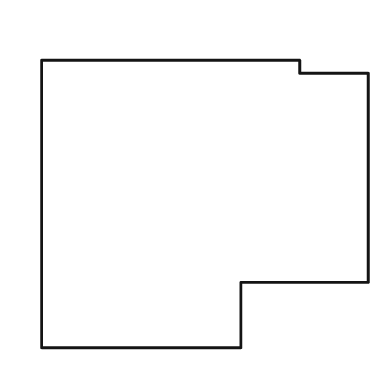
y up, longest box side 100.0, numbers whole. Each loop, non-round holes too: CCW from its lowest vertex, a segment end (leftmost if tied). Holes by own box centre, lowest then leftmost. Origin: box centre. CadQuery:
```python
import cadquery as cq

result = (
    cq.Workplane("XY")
    .moveTo(-50.0, -44.0)
    .lineTo(11.0, -44.0)
    .lineTo(11.0, -24.0)
    .lineTo(50.0, -24.0)
    .lineTo(50.0, 40.0)
    .lineTo(29.0, 40.0)
    .lineTo(29.0, 44.0)
    .lineTo(-50.0, 44.0)
    .close()
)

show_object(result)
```